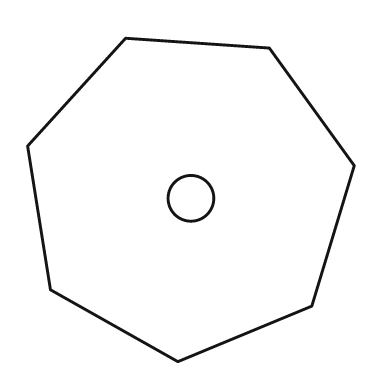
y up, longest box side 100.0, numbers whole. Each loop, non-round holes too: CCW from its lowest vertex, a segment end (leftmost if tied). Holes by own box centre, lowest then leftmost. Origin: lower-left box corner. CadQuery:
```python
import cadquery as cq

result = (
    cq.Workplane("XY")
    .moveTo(46.0, 0.0)
    .lineTo(87.0, 17.0)
    .lineTo(100.0, 60.0)
    .lineTo(74.0, 96.0)
    .lineTo(30.0, 99.0)
    .lineTo(0.0, 66.0)
    .lineTo(7.0, 22.0)
    .close()
    .moveTo(50.0, 50.0)
    .circle(7.0)
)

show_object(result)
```